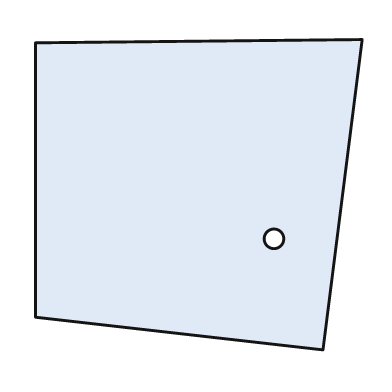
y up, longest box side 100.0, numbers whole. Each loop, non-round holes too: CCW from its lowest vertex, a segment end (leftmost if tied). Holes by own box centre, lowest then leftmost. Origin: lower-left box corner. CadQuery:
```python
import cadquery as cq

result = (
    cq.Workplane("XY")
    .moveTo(88.0, 0.0)
    .lineTo(100.0, 95.0)
    .lineTo(0.0, 94.0)
    .lineTo(0.0, 10.0)
    .close()
    .moveTo(73.0, 34.0)
    .circle(3.0)
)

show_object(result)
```